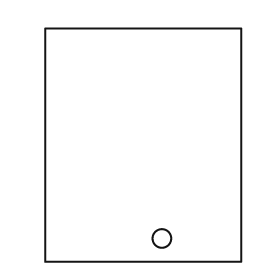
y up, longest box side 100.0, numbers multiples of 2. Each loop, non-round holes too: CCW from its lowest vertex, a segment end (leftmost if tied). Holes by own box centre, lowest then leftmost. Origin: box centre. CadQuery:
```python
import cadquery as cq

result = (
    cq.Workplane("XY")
    .moveTo(-42.0, -50.0)
    .lineTo(42.0, -50.0)
    .lineTo(42.0, 50.0)
    .lineTo(-42.0, 50.0)
    .close()
    .moveTo(8.0, -40.0)
    .circle(4.0)
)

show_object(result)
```